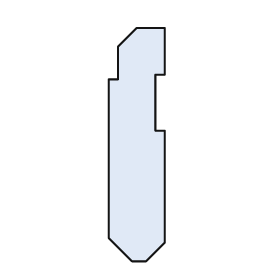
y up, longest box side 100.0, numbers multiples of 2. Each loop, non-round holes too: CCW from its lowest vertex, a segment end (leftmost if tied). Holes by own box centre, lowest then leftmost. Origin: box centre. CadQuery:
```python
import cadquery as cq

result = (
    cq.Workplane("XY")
    .moveTo(-2.0, -50.0)
    .lineTo(4.0, -50.0)
    .lineTo(12.0, -42.0)
    .lineTo(12.0, 6.0)
    .lineTo(8.0, 6.0)
    .lineTo(8.0, 30.0)
    .lineTo(12.0, 30.0)
    .lineTo(12.0, 50.0)
    .lineTo(0.0, 50.0)
    .lineTo(-8.0, 42.0)
    .lineTo(-8.0, 28.0)
    .lineTo(-12.0, 28.0)
    .lineTo(-12.0, -40.0)
    .close()
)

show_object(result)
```